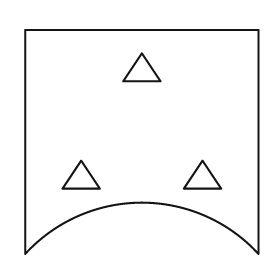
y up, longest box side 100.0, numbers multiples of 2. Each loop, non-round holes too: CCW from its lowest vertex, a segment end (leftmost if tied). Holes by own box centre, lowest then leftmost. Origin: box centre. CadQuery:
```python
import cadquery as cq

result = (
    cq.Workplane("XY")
    .moveTo(-50.0, -48.0)
    .threePointArc((0.0, -26.0), (50.0, -48.0))
    .lineTo(50.0, 48.0)
    .lineTo(-50.0, 48.0)
    .close()
    .moveTo(-34.0, -20.0)
    .lineTo(-18.0, -20.0)
    .lineTo(-26.0, -8.0)
    .close()
    .moveTo(18.0, -20.0)
    .lineTo(34.0, -20.0)
    .lineTo(26.0, -8.0)
    .close()
    .moveTo(-8.0, 26.0)
    .lineTo(8.0, 26.0)
    .lineTo(0.0, 38.0)
    .close()
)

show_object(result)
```